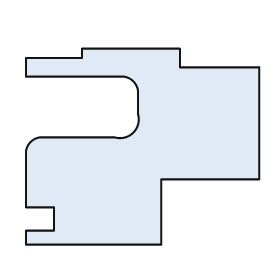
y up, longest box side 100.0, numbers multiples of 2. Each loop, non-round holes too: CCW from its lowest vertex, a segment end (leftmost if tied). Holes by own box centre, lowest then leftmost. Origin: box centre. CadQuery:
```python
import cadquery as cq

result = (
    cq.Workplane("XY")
    .moveTo(-50.0, -42.0)
    .lineTo(8.0, -42.0)
    .lineTo(8.0, -14.0)
    .lineTo(50.0, -14.0)
    .lineTo(50.0, 34.0)
    .lineTo(16.0, 34.0)
    .lineTo(16.0, 42.0)
    .lineTo(-26.0, 42.0)
    .lineTo(-26.0, 38.0)
    .lineTo(-50.0, 38.0)
    .lineTo(-50.0, 30.0)
    .lineTo(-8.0, 30.0)
    .threePointArc((-4.0, 28.0), (-2.0, 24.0))
    .lineTo(-2.0, 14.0)
    .threePointArc((-4.0, 6.0), (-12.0, 4.0))
    .lineTo(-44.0, 4.0)
    .threePointArc((-48.0, 2.0), (-50.0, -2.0))
    .lineTo(-50.0, -26.0)
    .lineTo(-38.0, -26.0)
    .lineTo(-38.0, -36.0)
    .lineTo(-50.0, -36.0)
    .close()
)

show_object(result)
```